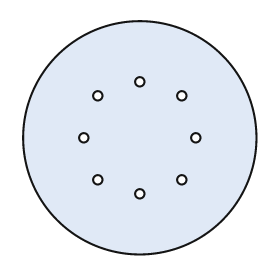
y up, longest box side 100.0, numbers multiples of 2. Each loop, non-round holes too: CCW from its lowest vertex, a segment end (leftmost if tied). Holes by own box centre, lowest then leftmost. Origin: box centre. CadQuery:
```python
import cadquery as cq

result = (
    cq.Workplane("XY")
    .moveTo(0.0, 0.0)
    .circle(50.0)
    .moveTo(0.0, -24.0)
    .circle(2.0)
    .moveTo(-18.0, -18.0)
    .circle(2.0)
    .moveTo(18.0, -18.0)
    .circle(2.0)
    .moveTo(-24.0, 0.0)
    .circle(2.0)
    .moveTo(24.0, 0.0)
    .circle(2.0)
    .moveTo(-18.0, 18.0)
    .circle(2.0)
    .moveTo(18.0, 18.0)
    .circle(2.0)
    .moveTo(0.0, 24.0)
    .circle(2.0)
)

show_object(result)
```